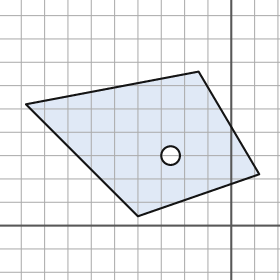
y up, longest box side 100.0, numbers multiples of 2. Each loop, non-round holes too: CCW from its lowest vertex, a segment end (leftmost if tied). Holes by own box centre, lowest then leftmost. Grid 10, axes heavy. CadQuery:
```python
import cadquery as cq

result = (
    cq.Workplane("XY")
    .moveTo(-40.0, 4.0)
    .lineTo(12.0, 22.0)
    .lineTo(-14.0, 66.0)
    .lineTo(-88.0, 52.0)
    .close()
    .moveTo(-26.0, 30.0)
    .circle(4.0)
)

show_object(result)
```